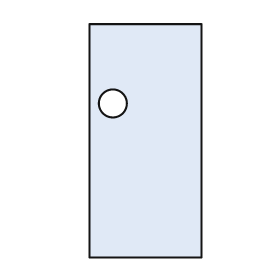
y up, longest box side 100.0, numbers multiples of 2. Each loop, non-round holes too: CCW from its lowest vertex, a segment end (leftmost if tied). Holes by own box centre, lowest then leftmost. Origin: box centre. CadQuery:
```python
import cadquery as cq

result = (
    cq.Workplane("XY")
    .moveTo(-24.0, -50.0)
    .lineTo(24.0, -50.0)
    .lineTo(24.0, 50.0)
    .lineTo(-24.0, 50.0)
    .close()
    .moveTo(-14.0, 16.0)
    .circle(6.0)
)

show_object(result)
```